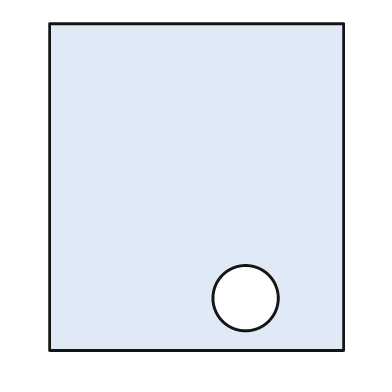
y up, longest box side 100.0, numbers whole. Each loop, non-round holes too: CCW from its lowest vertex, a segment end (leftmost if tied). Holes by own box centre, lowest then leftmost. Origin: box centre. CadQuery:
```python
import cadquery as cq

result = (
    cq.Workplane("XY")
    .moveTo(-45.0, -50.0)
    .lineTo(45.0, -50.0)
    .lineTo(45.0, 50.0)
    .lineTo(-45.0, 50.0)
    .close()
    .moveTo(15.0, -34.0)
    .circle(10.0)
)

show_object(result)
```